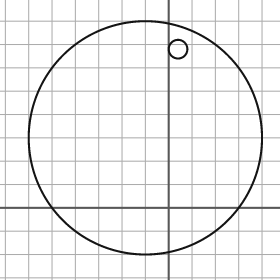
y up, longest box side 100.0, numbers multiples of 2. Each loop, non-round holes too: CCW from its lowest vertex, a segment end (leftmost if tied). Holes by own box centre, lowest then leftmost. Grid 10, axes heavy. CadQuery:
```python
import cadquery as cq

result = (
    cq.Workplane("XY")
    .moveTo(-10.0, 30.0)
    .circle(50.0)
    .moveTo(4.0, 68.0)
    .circle(4.0)
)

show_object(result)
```